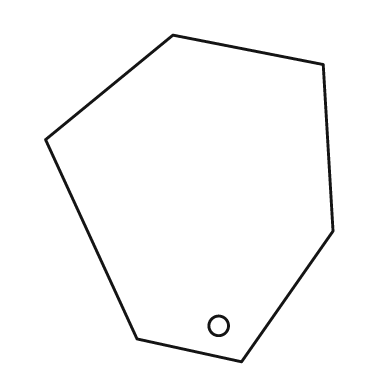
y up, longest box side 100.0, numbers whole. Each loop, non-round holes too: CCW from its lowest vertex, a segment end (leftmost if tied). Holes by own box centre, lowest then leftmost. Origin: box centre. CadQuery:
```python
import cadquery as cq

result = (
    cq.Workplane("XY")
    .moveTo(16.0, -50.0)
    .lineTo(44.0, -10.0)
    .lineTo(41.0, 41.0)
    .lineTo(-5.0, 50.0)
    .lineTo(-44.0, 18.0)
    .lineTo(-16.0, -43.0)
    .close()
    .moveTo(9.0, -39.0)
    .circle(3.0)
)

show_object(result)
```